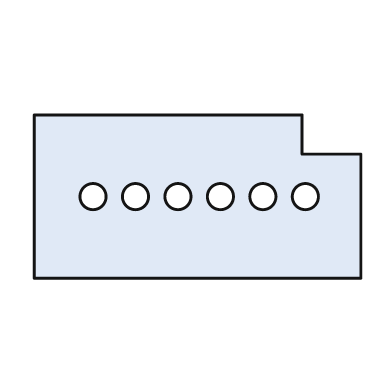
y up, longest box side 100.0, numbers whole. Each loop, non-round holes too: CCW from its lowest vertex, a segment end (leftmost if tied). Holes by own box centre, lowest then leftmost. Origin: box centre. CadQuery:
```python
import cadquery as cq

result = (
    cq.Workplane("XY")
    .moveTo(-50.0, -25.0)
    .lineTo(50.0, -25.0)
    .lineTo(50.0, 13.0)
    .lineTo(32.0, 13.0)
    .lineTo(32.0, 25.0)
    .lineTo(-50.0, 25.0)
    .close()
    .moveTo(-32.0, 0.0)
    .circle(4.0)
    .moveTo(-19.0, 0.0)
    .circle(4.0)
    .moveTo(-6.0, 0.0)
    .circle(4.0)
    .moveTo(7.0, 0.0)
    .circle(4.0)
    .moveTo(20.0, 0.0)
    .circle(4.0)
    .moveTo(33.0, 0.0)
    .circle(4.0)
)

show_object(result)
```